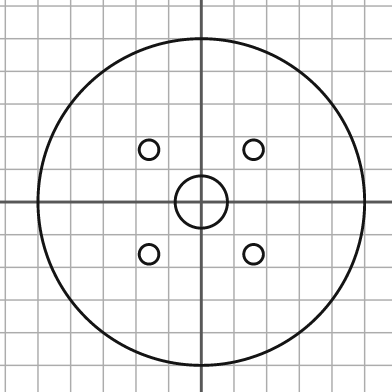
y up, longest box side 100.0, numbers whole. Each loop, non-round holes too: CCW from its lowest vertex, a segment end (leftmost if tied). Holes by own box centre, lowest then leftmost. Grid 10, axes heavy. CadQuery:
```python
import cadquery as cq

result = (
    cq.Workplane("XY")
    .moveTo(0.0, 0.0)
    .circle(50.0)
    .moveTo(-16.0, -16.0)
    .circle(3.0)
    .moveTo(16.0, -16.0)
    .circle(3.0)
    .moveTo(0.0, 0.0)
    .circle(8.0)
    .moveTo(-16.0, 16.0)
    .circle(3.0)
    .moveTo(16.0, 16.0)
    .circle(3.0)
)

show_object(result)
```